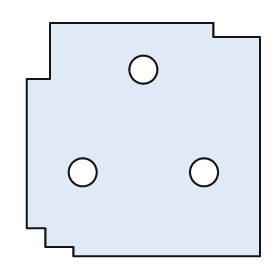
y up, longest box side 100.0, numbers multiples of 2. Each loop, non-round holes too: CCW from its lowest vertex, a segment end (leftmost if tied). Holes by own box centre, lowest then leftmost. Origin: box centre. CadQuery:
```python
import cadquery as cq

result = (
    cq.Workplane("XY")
    .moveTo(-30.0, -50.0)
    .lineTo(50.0, -50.0)
    .lineTo(50.0, 44.0)
    .lineTo(30.0, 44.0)
    .lineTo(30.0, 50.0)
    .lineTo(-40.0, 50.0)
    .lineTo(-40.0, 26.0)
    .lineTo(-50.0, 26.0)
    .lineTo(-50.0, -38.0)
    .lineTo(-42.0, -38.0)
    .lineTo(-42.0, -46.0)
    .lineTo(-30.0, -46.0)
    .close()
    .moveTo(-26.0, -14.0)
    .circle(6.0)
    .moveTo(26.0, -14.0)
    .circle(6.0)
    .moveTo(0.0, 30.0)
    .circle(6.0)
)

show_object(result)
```